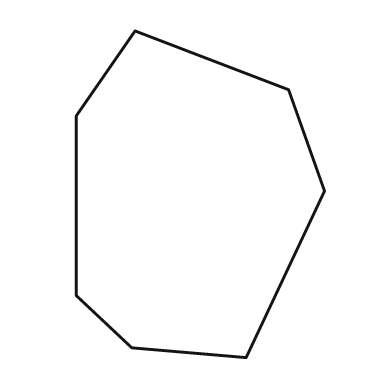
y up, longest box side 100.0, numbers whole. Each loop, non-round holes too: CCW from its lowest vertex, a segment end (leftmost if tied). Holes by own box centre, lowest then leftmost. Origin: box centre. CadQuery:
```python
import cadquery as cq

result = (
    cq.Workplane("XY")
    .moveTo(14.0, -50.0)
    .lineTo(38.0, 1.0)
    .lineTo(27.0, 32.0)
    .lineTo(-20.0, 50.0)
    .lineTo(-38.0, 24.0)
    .lineTo(-38.0, -31.0)
    .lineTo(-21.0, -47.0)
    .close()
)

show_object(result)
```